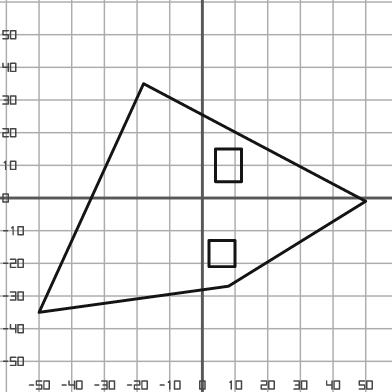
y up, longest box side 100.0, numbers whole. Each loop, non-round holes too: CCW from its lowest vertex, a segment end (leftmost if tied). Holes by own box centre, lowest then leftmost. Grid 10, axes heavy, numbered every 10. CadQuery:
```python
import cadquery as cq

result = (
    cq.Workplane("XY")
    .moveTo(-50.0, -35.0)
    .lineTo(8.0, -27.0)
    .lineTo(50.0, -1.0)
    .lineTo(-18.0, 35.0)
    .close()
    .moveTo(2.0, -21.0)
    .lineTo(10.0, -21.0)
    .lineTo(10.0, -13.0)
    .lineTo(2.0, -13.0)
    .close()
    .moveTo(4.0, 5.0)
    .lineTo(12.0, 5.0)
    .lineTo(12.0, 15.0)
    .lineTo(4.0, 15.0)
    .close()
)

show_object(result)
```